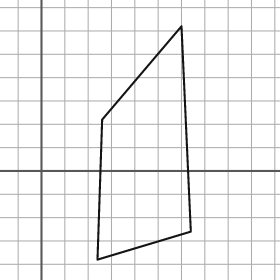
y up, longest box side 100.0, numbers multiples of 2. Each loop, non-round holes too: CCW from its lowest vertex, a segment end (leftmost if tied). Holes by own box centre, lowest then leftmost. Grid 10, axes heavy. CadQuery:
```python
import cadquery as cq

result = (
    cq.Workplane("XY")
    .moveTo(24.0, -38.0)
    .lineTo(64.0, -26.0)
    .lineTo(60.0, 62.0)
    .lineTo(26.0, 22.0)
    .close()
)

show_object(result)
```